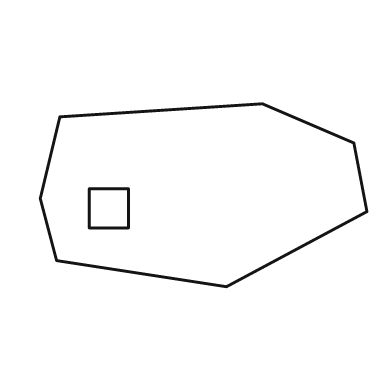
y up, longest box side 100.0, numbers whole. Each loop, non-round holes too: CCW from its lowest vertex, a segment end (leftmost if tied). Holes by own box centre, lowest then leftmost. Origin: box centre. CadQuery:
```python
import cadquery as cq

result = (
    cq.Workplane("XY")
    .moveTo(7.0, -28.0)
    .lineTo(50.0, -5.0)
    .lineTo(46.0, 16.0)
    .lineTo(18.0, 28.0)
    .lineTo(-44.0, 24.0)
    .lineTo(-50.0, -1.0)
    .lineTo(-45.0, -20.0)
    .close()
    .moveTo(-35.0, -10.0)
    .lineTo(-23.0, -10.0)
    .lineTo(-23.0, 2.0)
    .lineTo(-35.0, 2.0)
    .close()
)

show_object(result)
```